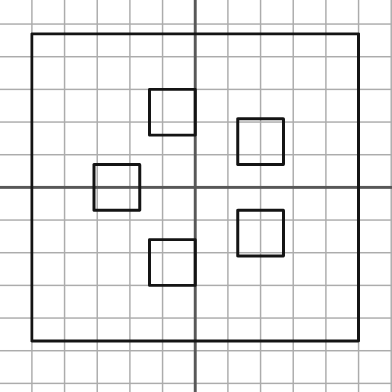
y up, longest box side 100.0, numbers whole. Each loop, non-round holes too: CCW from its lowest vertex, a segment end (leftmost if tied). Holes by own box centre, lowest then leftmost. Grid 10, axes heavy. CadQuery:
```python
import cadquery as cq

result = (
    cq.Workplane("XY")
    .moveTo(-50.0, -47.0)
    .lineTo(50.0, -47.0)
    .lineTo(50.0, 47.0)
    .lineTo(-50.0, 47.0)
    .close()
    .moveTo(-14.0, -30.0)
    .lineTo(0.0, -30.0)
    .lineTo(0.0, -16.0)
    .lineTo(-14.0, -16.0)
    .close()
    .moveTo(13.0, -21.0)
    .lineTo(27.0, -21.0)
    .lineTo(27.0, -7.0)
    .lineTo(13.0, -7.0)
    .close()
    .moveTo(-31.0, -7.0)
    .lineTo(-17.0, -7.0)
    .lineTo(-17.0, 7.0)
    .lineTo(-31.0, 7.0)
    .close()
    .moveTo(13.0, 7.0)
    .lineTo(27.0, 7.0)
    .lineTo(27.0, 21.0)
    .lineTo(13.0, 21.0)
    .close()
    .moveTo(-14.0, 16.0)
    .lineTo(0.0, 16.0)
    .lineTo(0.0, 30.0)
    .lineTo(-14.0, 30.0)
    .close()
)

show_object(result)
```